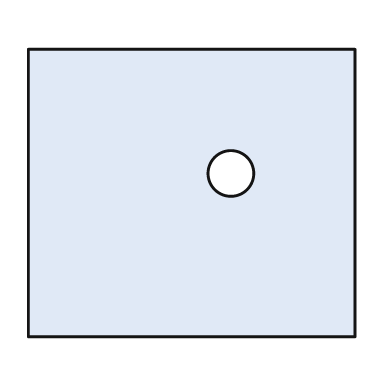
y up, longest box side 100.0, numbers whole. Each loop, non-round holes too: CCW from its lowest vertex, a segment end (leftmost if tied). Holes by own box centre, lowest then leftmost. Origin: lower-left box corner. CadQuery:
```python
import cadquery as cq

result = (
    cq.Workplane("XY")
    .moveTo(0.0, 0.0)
    .lineTo(100.0, 0.0)
    .lineTo(100.0, 88.0)
    .lineTo(0.0, 88.0)
    .close()
    .moveTo(62.0, 50.0)
    .circle(7.0)
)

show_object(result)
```